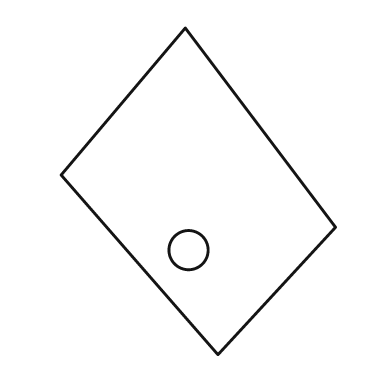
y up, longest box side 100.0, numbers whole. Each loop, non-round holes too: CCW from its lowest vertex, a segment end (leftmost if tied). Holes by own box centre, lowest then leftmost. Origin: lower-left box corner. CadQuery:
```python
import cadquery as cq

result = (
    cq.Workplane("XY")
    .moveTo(48.0, 0.0)
    .lineTo(84.0, 39.0)
    .lineTo(38.0, 100.0)
    .lineTo(0.0, 55.0)
    .close()
    .moveTo(39.0, 32.0)
    .circle(6.0)
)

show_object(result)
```